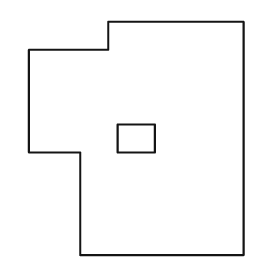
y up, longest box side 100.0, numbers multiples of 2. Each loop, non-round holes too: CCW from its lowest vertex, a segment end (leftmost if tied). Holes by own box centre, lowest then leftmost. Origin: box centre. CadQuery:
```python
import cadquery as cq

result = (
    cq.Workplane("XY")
    .moveTo(-24.0, -50.0)
    .lineTo(46.0, -50.0)
    .lineTo(46.0, 50.0)
    .lineTo(-12.0, 50.0)
    .lineTo(-12.0, 38.0)
    .lineTo(-46.0, 38.0)
    .lineTo(-46.0, -6.0)
    .lineTo(-24.0, -6.0)
    .close()
    .moveTo(-8.0, -6.0)
    .lineTo(8.0, -6.0)
    .lineTo(8.0, 6.0)
    .lineTo(-8.0, 6.0)
    .close()
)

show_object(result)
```